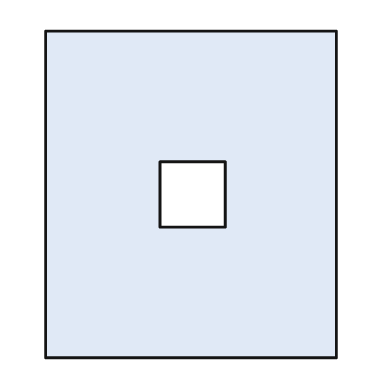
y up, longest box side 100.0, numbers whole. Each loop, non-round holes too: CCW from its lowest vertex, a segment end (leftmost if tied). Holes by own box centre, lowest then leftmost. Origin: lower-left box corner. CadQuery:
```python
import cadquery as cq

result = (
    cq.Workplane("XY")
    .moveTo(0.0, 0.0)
    .lineTo(89.0, 0.0)
    .lineTo(89.0, 100.0)
    .lineTo(0.0, 100.0)
    .close()
    .moveTo(35.0, 40.0)
    .lineTo(55.0, 40.0)
    .lineTo(55.0, 60.0)
    .lineTo(35.0, 60.0)
    .close()
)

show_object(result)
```